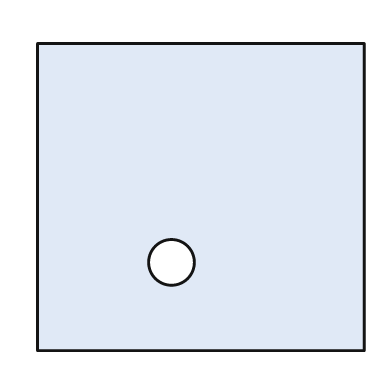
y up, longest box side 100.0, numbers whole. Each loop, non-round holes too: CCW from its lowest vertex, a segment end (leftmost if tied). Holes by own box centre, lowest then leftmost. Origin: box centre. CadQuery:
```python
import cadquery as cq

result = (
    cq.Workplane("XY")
    .moveTo(-50.0, -47.0)
    .lineTo(50.0, -47.0)
    .lineTo(50.0, 47.0)
    .lineTo(-50.0, 47.0)
    .close()
    .moveTo(-9.0, -20.0)
    .circle(7.0)
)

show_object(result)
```